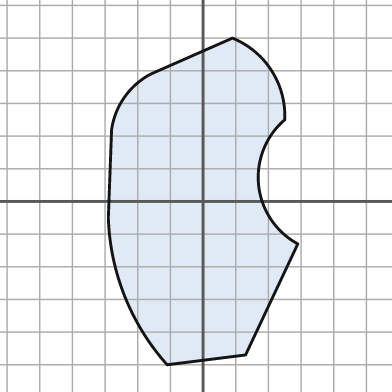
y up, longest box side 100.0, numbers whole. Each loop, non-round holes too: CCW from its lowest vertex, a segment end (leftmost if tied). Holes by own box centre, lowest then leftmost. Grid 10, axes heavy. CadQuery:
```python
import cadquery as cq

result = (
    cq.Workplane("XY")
    .moveTo(-11.0, -50.0)
    .lineTo(13.0, -47.0)
    .lineTo(29.0, -13.0)
    .threePointArc((17.0, 5.0), (25.0, 25.0))
    .threePointArc((21.0, 40.0), (9.0, 50.0))
    .lineTo(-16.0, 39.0)
    .threePointArc((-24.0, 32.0), (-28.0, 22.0))
    .lineTo(-29.0, -5.0)
    .threePointArc((-24.0, -29.0), (-11.0, -50.0))
    .close()
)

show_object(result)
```